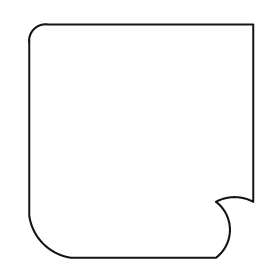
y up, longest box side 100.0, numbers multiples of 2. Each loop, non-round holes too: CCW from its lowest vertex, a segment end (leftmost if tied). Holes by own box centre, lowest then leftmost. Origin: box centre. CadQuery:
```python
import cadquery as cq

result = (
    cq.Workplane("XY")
    .moveTo(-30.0, -50.0)
    .lineTo(32.0, -50.0)
    .threePointArc((38.0, -38.0), (32.0, -26.0))
    .threePointArc((40.0, -24.0), (48.0, -26.0))
    .lineTo(48.0, 50.0)
    .lineTo(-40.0, 50.0)
    .threePointArc((-46.0, 48.0), (-48.0, 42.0))
    .lineTo(-48.0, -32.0)
    .threePointArc((-42.0, -44.0), (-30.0, -50.0))
    .close()
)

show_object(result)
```